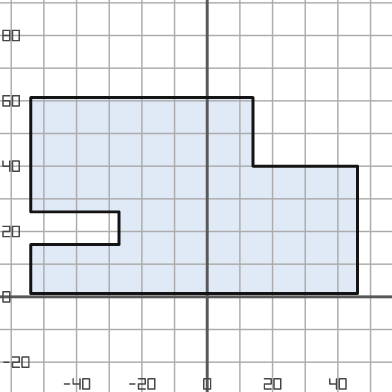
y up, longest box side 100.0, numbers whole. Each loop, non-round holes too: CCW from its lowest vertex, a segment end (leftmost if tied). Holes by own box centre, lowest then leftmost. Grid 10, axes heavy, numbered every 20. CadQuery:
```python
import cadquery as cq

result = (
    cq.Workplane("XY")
    .moveTo(-54.0, 1.0)
    .lineTo(46.0, 1.0)
    .lineTo(46.0, 40.0)
    .lineTo(14.0, 40.0)
    .lineTo(14.0, 61.0)
    .lineTo(-54.0, 61.0)
    .lineTo(-54.0, 26.0)
    .lineTo(-27.0, 26.0)
    .lineTo(-27.0, 16.0)
    .lineTo(-54.0, 16.0)
    .close()
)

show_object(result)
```